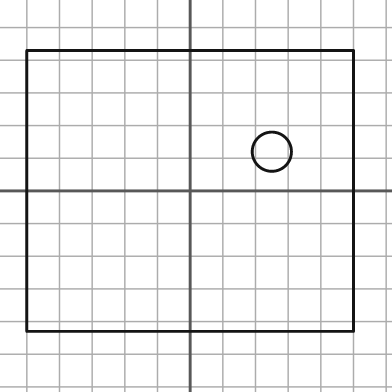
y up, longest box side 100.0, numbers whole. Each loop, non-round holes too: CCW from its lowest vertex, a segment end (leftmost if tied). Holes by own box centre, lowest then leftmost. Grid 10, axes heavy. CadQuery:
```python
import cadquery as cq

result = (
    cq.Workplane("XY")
    .moveTo(-50.0, -43.0)
    .lineTo(50.0, -43.0)
    .lineTo(50.0, 43.0)
    .lineTo(-50.0, 43.0)
    .close()
    .moveTo(25.0, 12.0)
    .circle(6.0)
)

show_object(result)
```